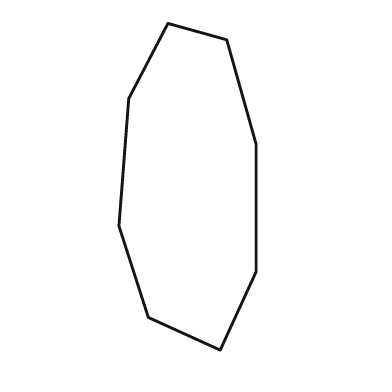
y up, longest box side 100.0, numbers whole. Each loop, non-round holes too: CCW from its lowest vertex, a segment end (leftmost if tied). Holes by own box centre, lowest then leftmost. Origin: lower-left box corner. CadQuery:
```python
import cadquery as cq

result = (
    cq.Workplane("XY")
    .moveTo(31.0, 0.0)
    .lineTo(42.0, 24.0)
    .lineTo(42.0, 63.0)
    .lineTo(33.0, 95.0)
    .lineTo(15.0, 100.0)
    .lineTo(3.0, 77.0)
    .lineTo(0.0, 38.0)
    .lineTo(9.0, 10.0)
    .close()
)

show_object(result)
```